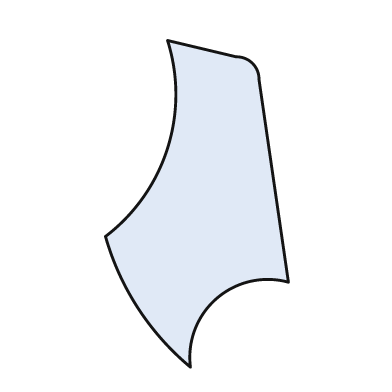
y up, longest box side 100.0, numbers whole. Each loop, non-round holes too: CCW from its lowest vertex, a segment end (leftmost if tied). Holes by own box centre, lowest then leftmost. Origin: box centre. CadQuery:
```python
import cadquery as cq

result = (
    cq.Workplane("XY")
    .moveTo(-2.0, -50.0)
    .threePointArc((6.0, -29.0), (28.0, -24.0))
    .lineTo(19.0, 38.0)
    .threePointArc((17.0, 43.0), (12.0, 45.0))
    .lineTo(-9.0, 50.0)
    .threePointArc((-9.0, 17.0), (-28.0, -10.0))
    .threePointArc((-18.0, -32.0), (-2.0, -50.0))
    .close()
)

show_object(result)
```